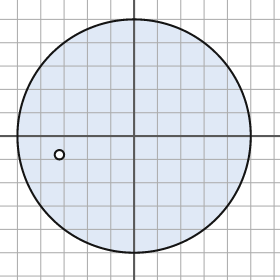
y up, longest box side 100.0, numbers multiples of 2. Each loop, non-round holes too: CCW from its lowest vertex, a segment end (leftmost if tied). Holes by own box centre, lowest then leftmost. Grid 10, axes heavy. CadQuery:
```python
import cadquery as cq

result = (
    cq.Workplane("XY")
    .moveTo(0.0, 0.0)
    .circle(50.0)
    .moveTo(-32.0, -8.0)
    .circle(2.0)
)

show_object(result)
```